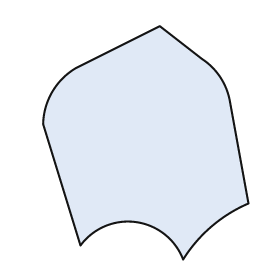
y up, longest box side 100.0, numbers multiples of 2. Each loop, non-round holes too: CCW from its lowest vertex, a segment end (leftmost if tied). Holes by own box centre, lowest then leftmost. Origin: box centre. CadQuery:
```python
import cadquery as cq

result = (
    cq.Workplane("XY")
    .moveTo(16.0, -50.0)
    .threePointArc((28.0, -36.0), (44.0, -26.0))
    .lineTo(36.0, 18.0)
    .threePointArc((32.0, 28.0), (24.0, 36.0))
    .lineTo(6.0, 50.0)
    .lineTo(-30.0, 32.0)
    .threePointArc((-40.0, 22.0), (-44.0, 8.0))
    .lineTo(-28.0, -44.0)
    .threePointArc((-4.0, -34.0), (16.0, -50.0))
    .close()
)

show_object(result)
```